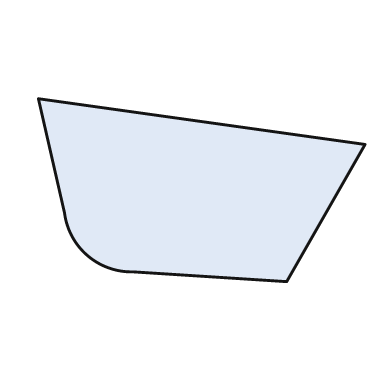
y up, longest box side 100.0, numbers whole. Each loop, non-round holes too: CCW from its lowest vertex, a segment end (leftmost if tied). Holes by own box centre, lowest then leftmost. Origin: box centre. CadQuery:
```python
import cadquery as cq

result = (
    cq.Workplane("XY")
    .moveTo(26.0, -28.0)
    .lineTo(50.0, 14.0)
    .lineTo(-50.0, 28.0)
    .lineTo(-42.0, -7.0)
    .threePointArc((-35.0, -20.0), (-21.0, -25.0))
    .close()
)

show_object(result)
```